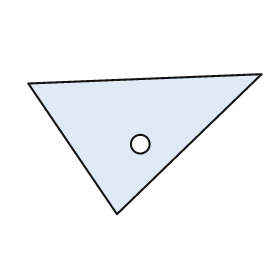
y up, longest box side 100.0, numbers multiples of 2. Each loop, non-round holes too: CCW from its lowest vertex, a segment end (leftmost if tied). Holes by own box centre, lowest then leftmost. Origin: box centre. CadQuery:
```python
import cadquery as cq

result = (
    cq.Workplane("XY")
    .moveTo(-12.0, -30.0)
    .lineTo(50.0, 30.0)
    .lineTo(-50.0, 26.0)
    .close()
    .moveTo(-2.0, 0.0)
    .circle(4.0)
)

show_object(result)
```